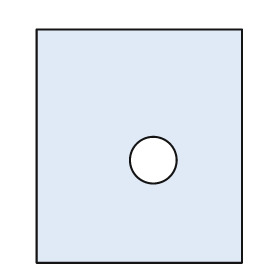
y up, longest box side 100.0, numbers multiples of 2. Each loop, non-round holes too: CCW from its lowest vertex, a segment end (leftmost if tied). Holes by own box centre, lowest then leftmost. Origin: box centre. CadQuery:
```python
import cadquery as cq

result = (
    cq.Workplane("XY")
    .moveTo(-44.0, -50.0)
    .lineTo(44.0, -50.0)
    .lineTo(44.0, 50.0)
    .lineTo(-44.0, 50.0)
    .close()
    .moveTo(6.0, -6.0)
    .circle(10.0)
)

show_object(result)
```